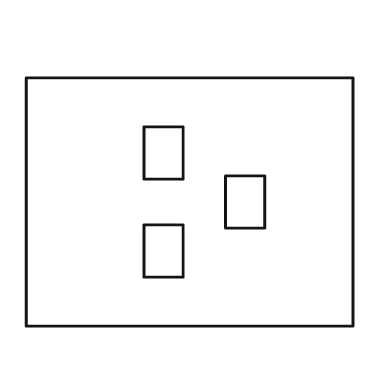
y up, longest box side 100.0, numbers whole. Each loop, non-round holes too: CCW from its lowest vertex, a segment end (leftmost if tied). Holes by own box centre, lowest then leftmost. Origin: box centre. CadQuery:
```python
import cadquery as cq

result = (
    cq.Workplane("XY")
    .moveTo(-50.0, -38.0)
    .lineTo(50.0, -38.0)
    .lineTo(50.0, 38.0)
    .lineTo(-50.0, 38.0)
    .close()
    .moveTo(-14.0, -23.0)
    .lineTo(-2.0, -23.0)
    .lineTo(-2.0, -7.0)
    .lineTo(-14.0, -7.0)
    .close()
    .moveTo(11.0, -8.0)
    .lineTo(23.0, -8.0)
    .lineTo(23.0, 8.0)
    .lineTo(11.0, 8.0)
    .close()
    .moveTo(-14.0, 7.0)
    .lineTo(-2.0, 7.0)
    .lineTo(-2.0, 23.0)
    .lineTo(-14.0, 23.0)
    .close()
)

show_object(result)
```